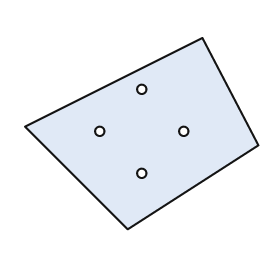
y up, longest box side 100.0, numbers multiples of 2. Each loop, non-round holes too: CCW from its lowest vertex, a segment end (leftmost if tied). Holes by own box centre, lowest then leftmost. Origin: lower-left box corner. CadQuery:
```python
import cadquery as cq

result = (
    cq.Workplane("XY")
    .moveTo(44.0, 0.0)
    .lineTo(100.0, 36.0)
    .lineTo(76.0, 82.0)
    .lineTo(0.0, 44.0)
    .close()
    .moveTo(50.0, 24.0)
    .circle(2.0)
    .moveTo(32.0, 42.0)
    .circle(2.0)
    .moveTo(68.0, 42.0)
    .circle(2.0)
    .moveTo(50.0, 60.0)
    .circle(2.0)
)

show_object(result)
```